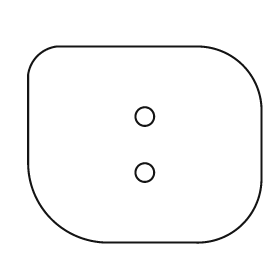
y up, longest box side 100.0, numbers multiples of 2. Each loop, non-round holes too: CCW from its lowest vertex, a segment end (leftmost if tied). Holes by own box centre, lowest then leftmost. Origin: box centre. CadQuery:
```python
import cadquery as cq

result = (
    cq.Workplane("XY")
    .moveTo(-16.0, -42.0)
    .lineTo(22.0, -42.0)
    .threePointArc((42.0, -34.0), (50.0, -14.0))
    .lineTo(50.0, 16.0)
    .threePointArc((42.0, 34.0), (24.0, 42.0))
    .lineTo(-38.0, 42.0)
    .threePointArc((-46.0, 38.0), (-50.0, 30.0))
    .lineTo(-50.0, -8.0)
    .threePointArc((-40.0, -32.0), (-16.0, -42.0))
    .close()
    .moveTo(0.0, -12.0)
    .circle(4.0)
    .moveTo(0.0, 12.0)
    .circle(4.0)
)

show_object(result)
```